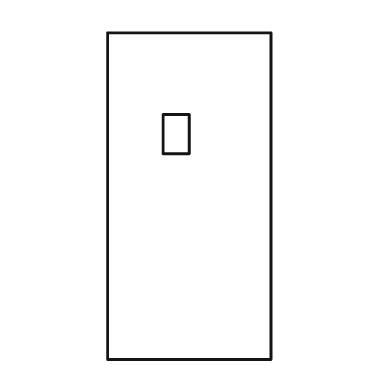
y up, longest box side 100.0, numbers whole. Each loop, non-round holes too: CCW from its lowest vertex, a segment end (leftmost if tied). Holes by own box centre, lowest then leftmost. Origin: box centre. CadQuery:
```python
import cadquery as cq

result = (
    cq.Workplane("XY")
    .moveTo(-25.0, -50.0)
    .lineTo(25.0, -50.0)
    .lineTo(25.0, 50.0)
    .lineTo(-25.0, 50.0)
    .close()
    .moveTo(-8.0, 13.0)
    .lineTo(0.0, 13.0)
    .lineTo(0.0, 25.0)
    .lineTo(-8.0, 25.0)
    .close()
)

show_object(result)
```